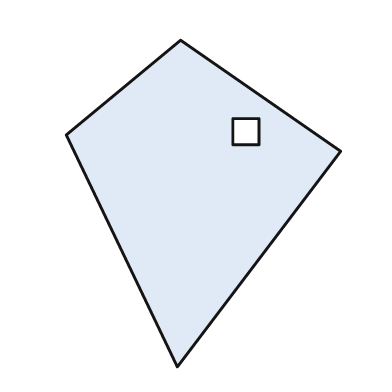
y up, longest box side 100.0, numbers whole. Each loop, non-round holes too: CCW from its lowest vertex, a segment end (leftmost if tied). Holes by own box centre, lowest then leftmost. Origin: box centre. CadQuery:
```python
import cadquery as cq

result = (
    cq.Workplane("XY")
    .moveTo(-8.0, -50.0)
    .lineTo(42.0, 16.0)
    .lineTo(-7.0, 50.0)
    .lineTo(-42.0, 21.0)
    .close()
    .moveTo(9.0, 18.0)
    .lineTo(17.0, 18.0)
    .lineTo(17.0, 26.0)
    .lineTo(9.0, 26.0)
    .close()
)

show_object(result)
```